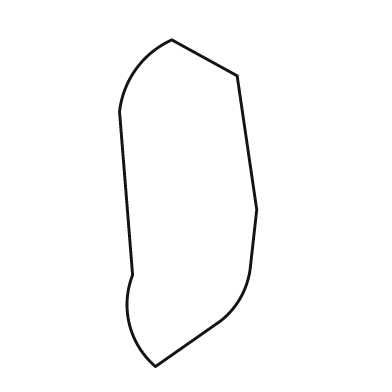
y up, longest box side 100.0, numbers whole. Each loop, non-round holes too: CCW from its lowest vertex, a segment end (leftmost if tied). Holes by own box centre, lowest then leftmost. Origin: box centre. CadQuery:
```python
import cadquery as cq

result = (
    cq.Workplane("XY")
    .moveTo(-10.0, -50.0)
    .lineTo(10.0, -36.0)
    .threePointArc((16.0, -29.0), (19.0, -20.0))
    .lineTo(21.0, -2.0)
    .lineTo(15.0, 39.0)
    .lineTo(-5.0, 50.0)
    .threePointArc((-16.0, 41.0), (-21.0, 28.0))
    .lineTo(-17.0, -22.0)
    .threePointArc((-18.0, -37.0), (-10.0, -50.0))
    .close()
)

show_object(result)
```